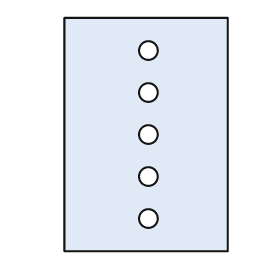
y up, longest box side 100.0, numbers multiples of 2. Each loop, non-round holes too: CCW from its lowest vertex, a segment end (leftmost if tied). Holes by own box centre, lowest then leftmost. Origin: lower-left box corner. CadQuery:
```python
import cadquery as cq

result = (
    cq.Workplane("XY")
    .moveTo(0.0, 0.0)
    .lineTo(70.0, 0.0)
    .lineTo(70.0, 100.0)
    .lineTo(0.0, 100.0)
    .close()
    .moveTo(36.0, 14.0)
    .circle(4.0)
    .moveTo(36.0, 32.0)
    .circle(4.0)
    .moveTo(36.0, 50.0)
    .circle(4.0)
    .moveTo(36.0, 68.0)
    .circle(4.0)
    .moveTo(36.0, 86.0)
    .circle(4.0)
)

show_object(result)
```